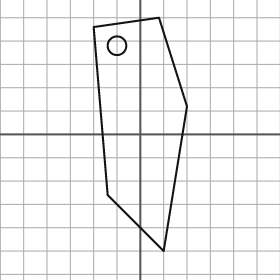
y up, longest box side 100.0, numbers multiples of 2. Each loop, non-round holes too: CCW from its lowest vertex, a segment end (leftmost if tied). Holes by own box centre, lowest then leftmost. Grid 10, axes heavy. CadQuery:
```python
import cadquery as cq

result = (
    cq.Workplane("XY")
    .moveTo(10.0, -50.0)
    .lineTo(20.0, 12.0)
    .lineTo(8.0, 50.0)
    .lineTo(-20.0, 46.0)
    .lineTo(-14.0, -26.0)
    .close()
    .moveTo(-10.0, 38.0)
    .circle(4.0)
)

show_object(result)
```